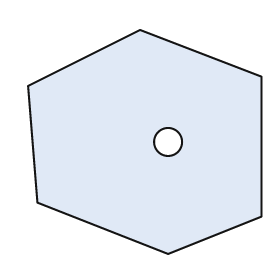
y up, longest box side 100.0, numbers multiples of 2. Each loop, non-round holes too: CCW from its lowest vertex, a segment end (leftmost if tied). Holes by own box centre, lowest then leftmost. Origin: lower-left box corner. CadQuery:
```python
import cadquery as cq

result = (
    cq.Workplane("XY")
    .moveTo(60.0, 0.0)
    .lineTo(100.0, 16.0)
    .lineTo(100.0, 76.0)
    .lineTo(48.0, 96.0)
    .lineTo(0.0, 72.0)
    .lineTo(4.0, 22.0)
    .close()
    .moveTo(60.0, 48.0)
    .circle(6.0)
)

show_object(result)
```